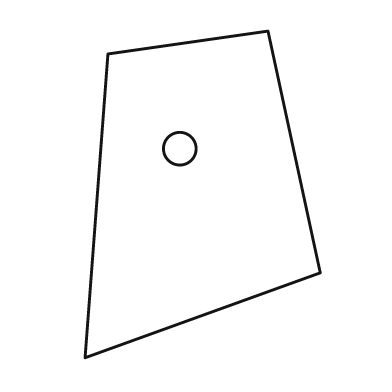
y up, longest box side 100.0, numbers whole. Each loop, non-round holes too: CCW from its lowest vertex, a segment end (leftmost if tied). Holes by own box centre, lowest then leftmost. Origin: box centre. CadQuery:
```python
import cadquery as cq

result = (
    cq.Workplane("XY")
    .moveTo(-36.0, -50.0)
    .lineTo(36.0, -24.0)
    .lineTo(20.0, 50.0)
    .lineTo(-29.0, 43.0)
    .close()
    .moveTo(-7.0, 14.0)
    .circle(5.0)
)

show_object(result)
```